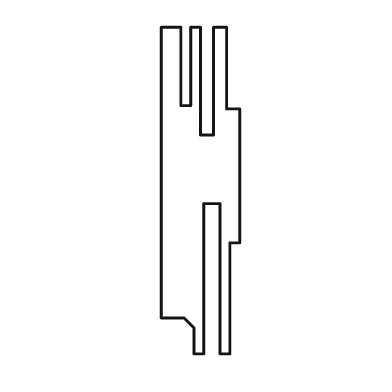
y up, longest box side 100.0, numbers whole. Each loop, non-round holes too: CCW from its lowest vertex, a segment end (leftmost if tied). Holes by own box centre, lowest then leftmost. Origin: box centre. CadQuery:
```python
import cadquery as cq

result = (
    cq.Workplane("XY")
    .moveTo(-2.0, -50.0)
    .lineTo(1.0, -50.0)
    .lineTo(1.0, -4.0)
    .lineTo(6.0, -4.0)
    .lineTo(6.0, -50.0)
    .lineTo(9.0, -50.0)
    .lineTo(9.0, -16.0)
    .lineTo(12.0, -16.0)
    .lineTo(12.0, 25.0)
    .lineTo(8.0, 25.0)
    .lineTo(8.0, 50.0)
    .lineTo(4.0, 50.0)
    .lineTo(4.0, 17.0)
    .lineTo(0.0, 17.0)
    .lineTo(0.0, 50.0)
    .lineTo(-3.0, 50.0)
    .lineTo(-3.0, 26.0)
    .lineTo(-6.0, 26.0)
    .lineTo(-6.0, 50.0)
    .lineTo(-12.0, 50.0)
    .lineTo(-12.0, -39.0)
    .lineTo(-5.0, -39.0)
    .lineTo(-2.0, -42.0)
    .close()
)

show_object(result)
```